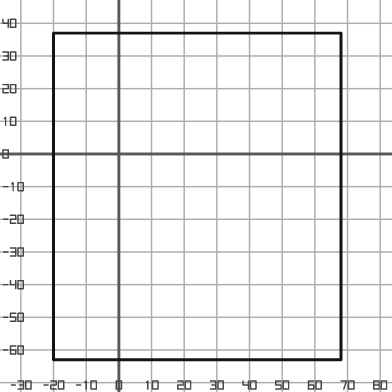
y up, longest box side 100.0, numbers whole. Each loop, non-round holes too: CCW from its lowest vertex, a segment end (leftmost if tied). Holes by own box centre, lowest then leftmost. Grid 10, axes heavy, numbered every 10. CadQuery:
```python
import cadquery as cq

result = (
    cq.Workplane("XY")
    .moveTo(-20.0, -63.0)
    .lineTo(68.0, -63.0)
    .lineTo(68.0, 37.0)
    .lineTo(-20.0, 37.0)
    .close()
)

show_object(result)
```